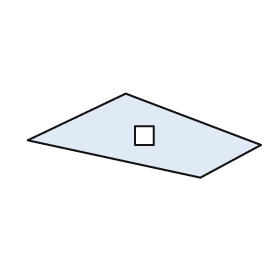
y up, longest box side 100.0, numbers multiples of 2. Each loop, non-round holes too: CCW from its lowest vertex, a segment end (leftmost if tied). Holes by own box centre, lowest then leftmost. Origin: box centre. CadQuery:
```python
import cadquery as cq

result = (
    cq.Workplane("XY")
    .moveTo(24.0, -18.0)
    .lineTo(50.0, -4.0)
    .lineTo(-8.0, 18.0)
    .lineTo(-50.0, -2.0)
    .close()
    .moveTo(-4.0, -4.0)
    .lineTo(4.0, -4.0)
    .lineTo(4.0, 4.0)
    .lineTo(-4.0, 4.0)
    .close()
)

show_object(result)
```